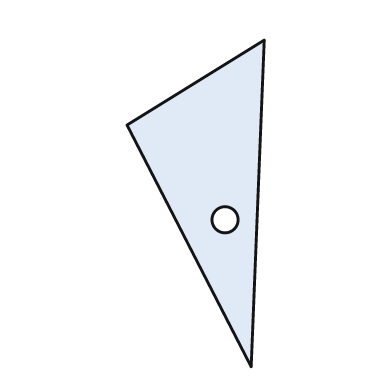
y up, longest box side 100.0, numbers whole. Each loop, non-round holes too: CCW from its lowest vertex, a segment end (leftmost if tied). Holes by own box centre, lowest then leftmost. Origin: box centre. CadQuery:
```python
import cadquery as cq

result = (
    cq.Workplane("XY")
    .moveTo(17.0, -50.0)
    .lineTo(21.0, 50.0)
    .lineTo(-21.0, 24.0)
    .close()
    .moveTo(9.0, -5.0)
    .circle(4.0)
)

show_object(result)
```